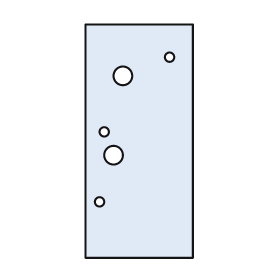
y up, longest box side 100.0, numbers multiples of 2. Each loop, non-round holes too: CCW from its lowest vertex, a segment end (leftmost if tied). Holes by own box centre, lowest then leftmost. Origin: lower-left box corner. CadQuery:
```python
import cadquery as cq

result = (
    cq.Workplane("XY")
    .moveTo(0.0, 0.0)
    .lineTo(46.0, 0.0)
    .lineTo(46.0, 100.0)
    .lineTo(0.0, 100.0)
    .close()
    .moveTo(6.0, 24.0)
    .circle(2.0)
    .moveTo(12.0, 44.0)
    .circle(4.0)
    .moveTo(8.0, 54.0)
    .circle(2.0)
    .moveTo(16.0, 78.0)
    .circle(4.0)
    .moveTo(36.0, 86.0)
    .circle(2.0)
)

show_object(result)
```